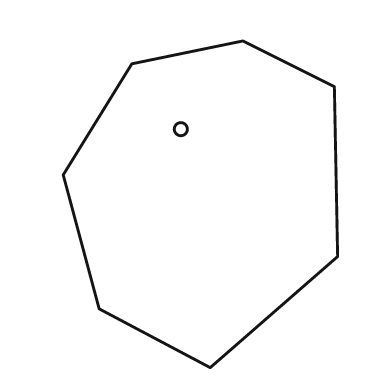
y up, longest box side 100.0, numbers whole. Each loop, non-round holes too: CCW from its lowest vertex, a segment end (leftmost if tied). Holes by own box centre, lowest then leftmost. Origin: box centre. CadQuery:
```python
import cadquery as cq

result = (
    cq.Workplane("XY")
    .moveTo(3.0, -50.0)
    .lineTo(42.0, -16.0)
    .lineTo(41.0, 36.0)
    .lineTo(13.0, 50.0)
    .lineTo(-21.0, 43.0)
    .lineTo(-42.0, 9.0)
    .lineTo(-31.0, -32.0)
    .close()
    .moveTo(-6.0, 23.0)
    .circle(2.0)
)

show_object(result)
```